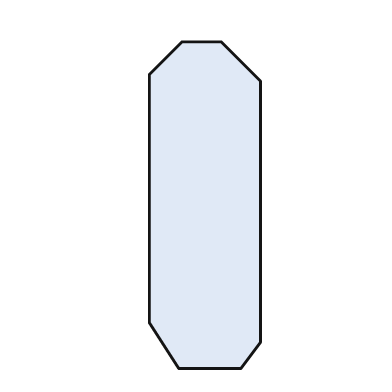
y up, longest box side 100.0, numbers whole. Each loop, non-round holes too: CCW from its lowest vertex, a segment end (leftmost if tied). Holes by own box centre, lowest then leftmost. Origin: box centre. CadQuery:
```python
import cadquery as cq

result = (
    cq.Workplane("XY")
    .moveTo(-8.0, -50.0)
    .lineTo(11.0, -50.0)
    .lineTo(17.0, -42.0)
    .lineTo(17.0, 38.0)
    .lineTo(5.0, 50.0)
    .lineTo(-7.0, 50.0)
    .lineTo(-17.0, 40.0)
    .lineTo(-17.0, -36.0)
    .close()
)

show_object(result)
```